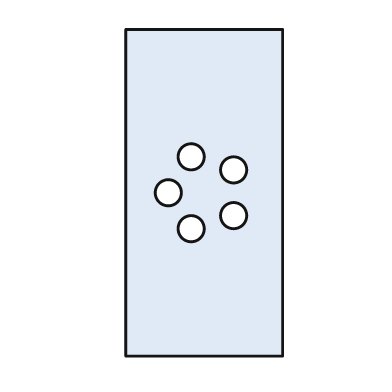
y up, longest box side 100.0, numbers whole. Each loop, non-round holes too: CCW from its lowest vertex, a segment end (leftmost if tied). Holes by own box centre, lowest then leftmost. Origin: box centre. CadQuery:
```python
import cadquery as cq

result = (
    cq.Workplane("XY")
    .moveTo(-24.0, -50.0)
    .lineTo(24.0, -50.0)
    .lineTo(24.0, 50.0)
    .lineTo(-24.0, 50.0)
    .close()
    .moveTo(-4.0, -11.0)
    .circle(4.0)
    .moveTo(9.0, -7.0)
    .circle(4.0)
    .moveTo(-11.0, 0.0)
    .circle(4.0)
    .moveTo(9.0, 7.0)
    .circle(4.0)
    .moveTo(-4.0, 11.0)
    .circle(4.0)
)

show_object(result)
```